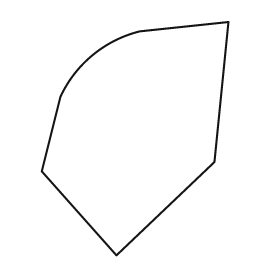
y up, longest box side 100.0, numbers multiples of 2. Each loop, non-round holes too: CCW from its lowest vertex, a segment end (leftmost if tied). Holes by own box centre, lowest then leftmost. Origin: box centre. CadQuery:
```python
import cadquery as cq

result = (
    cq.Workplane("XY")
    .moveTo(-8.0, -50.0)
    .lineTo(34.0, -10.0)
    .lineTo(40.0, 50.0)
    .lineTo(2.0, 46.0)
    .threePointArc((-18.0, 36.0), (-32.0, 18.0))
    .lineTo(-40.0, -14.0)
    .close()
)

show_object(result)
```